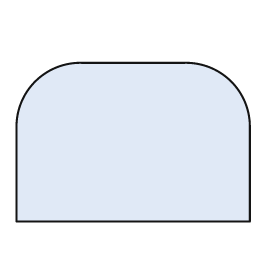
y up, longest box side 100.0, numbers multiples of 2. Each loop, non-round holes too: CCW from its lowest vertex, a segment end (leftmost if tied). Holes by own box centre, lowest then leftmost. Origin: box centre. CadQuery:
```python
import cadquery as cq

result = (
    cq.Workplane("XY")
    .moveTo(-50.0, -34.0)
    .lineTo(50.0, -34.0)
    .lineTo(50.0, 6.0)
    .threePointArc((42.0, 26.0), (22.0, 34.0))
    .lineTo(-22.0, 34.0)
    .threePointArc((-42.0, 26.0), (-50.0, 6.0))
    .close()
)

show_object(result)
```